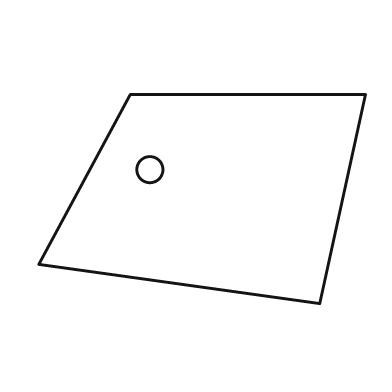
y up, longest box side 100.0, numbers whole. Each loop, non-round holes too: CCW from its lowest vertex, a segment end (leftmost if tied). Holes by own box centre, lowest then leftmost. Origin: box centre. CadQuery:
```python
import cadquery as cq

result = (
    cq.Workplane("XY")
    .moveTo(36.0, -32.0)
    .lineTo(50.0, 32.0)
    .lineTo(-22.0, 32.0)
    .lineTo(-50.0, -20.0)
    .close()
    .moveTo(-16.0, 9.0)
    .circle(4.0)
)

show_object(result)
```